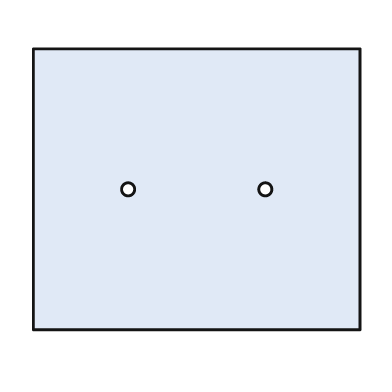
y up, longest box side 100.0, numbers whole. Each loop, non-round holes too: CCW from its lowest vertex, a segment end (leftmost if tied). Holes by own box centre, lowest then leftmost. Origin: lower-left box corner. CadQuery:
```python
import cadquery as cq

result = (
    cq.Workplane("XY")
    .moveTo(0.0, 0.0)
    .lineTo(100.0, 0.0)
    .lineTo(100.0, 86.0)
    .lineTo(0.0, 86.0)
    .close()
    .moveTo(29.0, 43.0)
    .circle(2.0)
    .moveTo(71.0, 43.0)
    .circle(2.0)
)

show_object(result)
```